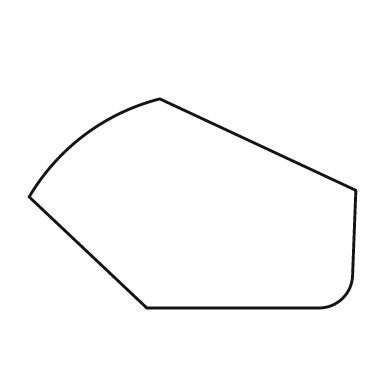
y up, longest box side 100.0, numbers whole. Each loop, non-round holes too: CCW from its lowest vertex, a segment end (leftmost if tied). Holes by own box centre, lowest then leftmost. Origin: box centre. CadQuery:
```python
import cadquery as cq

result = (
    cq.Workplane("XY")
    .moveTo(-14.0, -32.0)
    .lineTo(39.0, -32.0)
    .threePointArc((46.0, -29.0), (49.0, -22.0))
    .lineTo(50.0, 4.0)
    .lineTo(-10.0, 32.0)
    .threePointArc((-33.0, 21.0), (-50.0, 2.0))
    .close()
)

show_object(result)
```